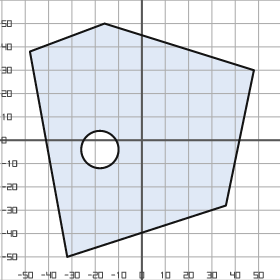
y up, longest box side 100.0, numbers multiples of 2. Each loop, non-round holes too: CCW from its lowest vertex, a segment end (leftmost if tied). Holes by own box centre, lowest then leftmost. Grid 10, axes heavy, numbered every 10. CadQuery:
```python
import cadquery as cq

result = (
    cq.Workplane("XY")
    .moveTo(-32.0, -50.0)
    .lineTo(36.0, -28.0)
    .lineTo(48.0, 30.0)
    .lineTo(-16.0, 50.0)
    .lineTo(-48.0, 38.0)
    .close()
    .moveTo(-18.0, -4.0)
    .circle(8.0)
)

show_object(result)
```